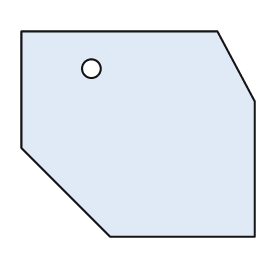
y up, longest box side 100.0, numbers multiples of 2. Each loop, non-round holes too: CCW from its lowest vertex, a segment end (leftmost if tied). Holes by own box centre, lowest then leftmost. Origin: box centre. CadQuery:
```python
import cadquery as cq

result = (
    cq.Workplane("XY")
    .moveTo(-12.0, -44.0)
    .lineTo(50.0, -44.0)
    .lineTo(50.0, 14.0)
    .lineTo(34.0, 44.0)
    .lineTo(-50.0, 44.0)
    .lineTo(-50.0, -6.0)
    .close()
    .moveTo(-20.0, 28.0)
    .circle(4.0)
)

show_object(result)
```